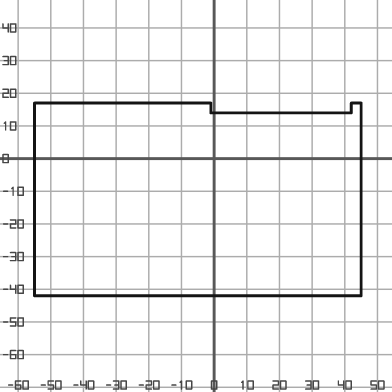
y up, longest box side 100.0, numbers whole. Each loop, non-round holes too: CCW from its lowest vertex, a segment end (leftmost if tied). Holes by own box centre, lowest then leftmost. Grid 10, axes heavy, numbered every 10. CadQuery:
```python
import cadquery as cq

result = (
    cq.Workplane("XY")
    .moveTo(-55.0, -42.0)
    .lineTo(45.0, -42.0)
    .lineTo(45.0, 17.0)
    .lineTo(42.0, 17.0)
    .lineTo(42.0, 14.0)
    .lineTo(-1.0, 14.0)
    .lineTo(-1.0, 17.0)
    .lineTo(-55.0, 17.0)
    .close()
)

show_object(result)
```